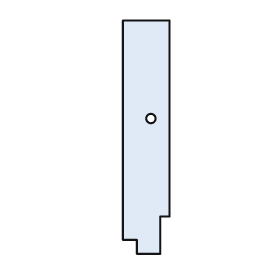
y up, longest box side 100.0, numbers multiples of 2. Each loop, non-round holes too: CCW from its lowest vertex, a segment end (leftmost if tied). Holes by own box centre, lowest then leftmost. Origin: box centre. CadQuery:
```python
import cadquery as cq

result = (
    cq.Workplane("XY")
    .moveTo(-4.0, -50.0)
    .lineTo(6.0, -50.0)
    .lineTo(6.0, -34.0)
    .lineTo(10.0, -34.0)
    .lineTo(10.0, 50.0)
    .lineTo(-10.0, 50.0)
    .lineTo(-10.0, -44.0)
    .lineTo(-4.0, -44.0)
    .close()
    .moveTo(2.0, 8.0)
    .circle(2.0)
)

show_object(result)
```